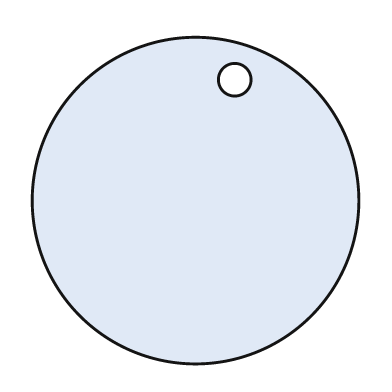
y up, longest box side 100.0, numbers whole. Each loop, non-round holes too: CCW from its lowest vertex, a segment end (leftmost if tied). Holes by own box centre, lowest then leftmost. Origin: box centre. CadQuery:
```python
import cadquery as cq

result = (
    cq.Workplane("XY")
    .moveTo(0.0, 0.0)
    .circle(50.0)
    .moveTo(12.0, 37.0)
    .circle(5.0)
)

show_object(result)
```